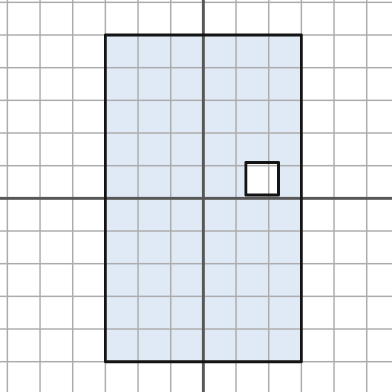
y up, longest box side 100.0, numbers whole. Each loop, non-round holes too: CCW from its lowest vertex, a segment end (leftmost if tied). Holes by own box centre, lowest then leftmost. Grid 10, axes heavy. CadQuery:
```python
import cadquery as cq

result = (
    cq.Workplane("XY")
    .moveTo(-30.0, -50.0)
    .lineTo(30.0, -50.0)
    .lineTo(30.0, 50.0)
    .lineTo(-30.0, 50.0)
    .close()
    .moveTo(13.0, 1.0)
    .lineTo(23.0, 1.0)
    .lineTo(23.0, 11.0)
    .lineTo(13.0, 11.0)
    .close()
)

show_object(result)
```